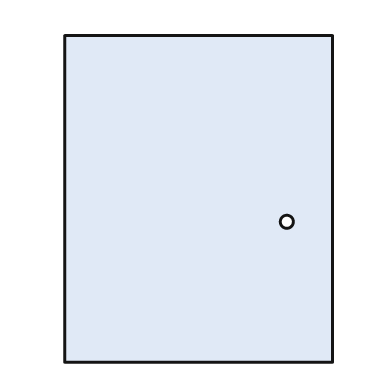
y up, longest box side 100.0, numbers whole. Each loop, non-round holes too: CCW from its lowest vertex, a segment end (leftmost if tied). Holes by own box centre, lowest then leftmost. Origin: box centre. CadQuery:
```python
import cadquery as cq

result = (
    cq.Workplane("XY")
    .moveTo(-41.0, -50.0)
    .lineTo(41.0, -50.0)
    .lineTo(41.0, 50.0)
    .lineTo(-41.0, 50.0)
    .close()
    .moveTo(27.0, -7.0)
    .circle(2.0)
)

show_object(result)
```